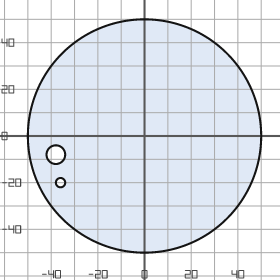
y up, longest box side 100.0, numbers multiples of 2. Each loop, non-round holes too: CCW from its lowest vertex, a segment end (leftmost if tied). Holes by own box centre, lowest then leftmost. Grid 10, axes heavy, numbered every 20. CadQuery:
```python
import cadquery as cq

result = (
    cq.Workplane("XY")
    .moveTo(0.0, 0.0)
    .circle(50.0)
    .moveTo(-36.0, -20.0)
    .circle(2.0)
    .moveTo(-38.0, -8.0)
    .circle(4.0)
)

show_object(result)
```